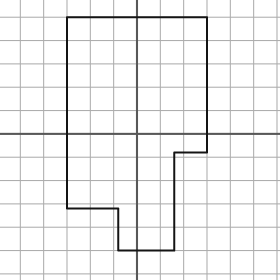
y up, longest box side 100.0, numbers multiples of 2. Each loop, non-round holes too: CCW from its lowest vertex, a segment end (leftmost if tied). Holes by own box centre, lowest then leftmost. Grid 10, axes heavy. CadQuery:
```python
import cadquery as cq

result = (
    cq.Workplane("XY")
    .moveTo(-8.0, -50.0)
    .lineTo(16.0, -50.0)
    .lineTo(16.0, -8.0)
    .lineTo(30.0, -8.0)
    .lineTo(30.0, 50.0)
    .lineTo(-30.0, 50.0)
    .lineTo(-30.0, -32.0)
    .lineTo(-8.0, -32.0)
    .close()
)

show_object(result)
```